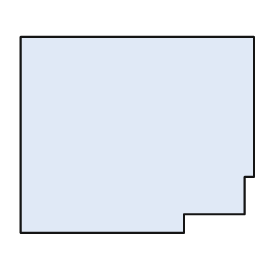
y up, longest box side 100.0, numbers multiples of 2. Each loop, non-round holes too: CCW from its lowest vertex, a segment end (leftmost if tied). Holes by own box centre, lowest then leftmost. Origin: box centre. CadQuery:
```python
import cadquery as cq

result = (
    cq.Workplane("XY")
    .moveTo(-50.0, -42.0)
    .lineTo(20.0, -42.0)
    .lineTo(20.0, -34.0)
    .lineTo(46.0, -34.0)
    .lineTo(46.0, -18.0)
    .lineTo(50.0, -18.0)
    .lineTo(50.0, 42.0)
    .lineTo(-50.0, 42.0)
    .close()
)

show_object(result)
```